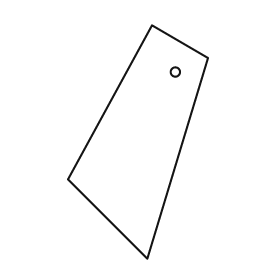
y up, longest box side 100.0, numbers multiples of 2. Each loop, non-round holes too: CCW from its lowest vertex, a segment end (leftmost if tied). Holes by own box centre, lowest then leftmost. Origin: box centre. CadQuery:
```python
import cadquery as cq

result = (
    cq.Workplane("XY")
    .moveTo(4.0, -50.0)
    .lineTo(30.0, 36.0)
    .lineTo(6.0, 50.0)
    .lineTo(-30.0, -16.0)
    .close()
    .moveTo(16.0, 30.0)
    .circle(2.0)
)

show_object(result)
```